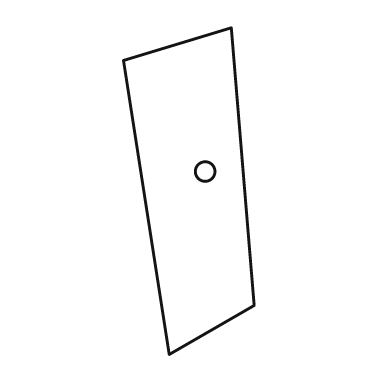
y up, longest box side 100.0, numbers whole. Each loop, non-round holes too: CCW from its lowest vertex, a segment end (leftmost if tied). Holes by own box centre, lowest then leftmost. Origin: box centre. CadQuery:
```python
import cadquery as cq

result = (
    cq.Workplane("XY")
    .moveTo(-6.0, -50.0)
    .lineTo(20.0, -35.0)
    .lineTo(13.0, 50.0)
    .lineTo(-20.0, 40.0)
    .close()
    .moveTo(5.0, 6.0)
    .circle(3.0)
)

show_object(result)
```